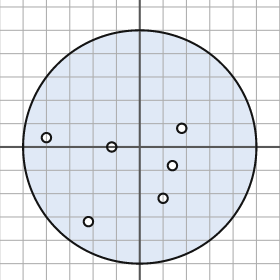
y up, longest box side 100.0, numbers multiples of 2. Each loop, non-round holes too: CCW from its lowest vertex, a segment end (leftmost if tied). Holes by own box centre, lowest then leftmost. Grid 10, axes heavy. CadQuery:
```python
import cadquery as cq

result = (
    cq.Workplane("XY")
    .moveTo(0.0, 0.0)
    .circle(50.0)
    .moveTo(-22.0, -32.0)
    .circle(2.0)
    .moveTo(10.0, -22.0)
    .circle(2.0)
    .moveTo(14.0, -8.0)
    .circle(2.0)
    .moveTo(-12.0, 0.0)
    .circle(2.0)
    .moveTo(-40.0, 4.0)
    .circle(2.0)
    .moveTo(18.0, 8.0)
    .circle(2.0)
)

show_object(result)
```